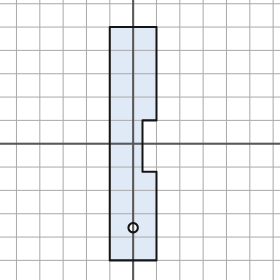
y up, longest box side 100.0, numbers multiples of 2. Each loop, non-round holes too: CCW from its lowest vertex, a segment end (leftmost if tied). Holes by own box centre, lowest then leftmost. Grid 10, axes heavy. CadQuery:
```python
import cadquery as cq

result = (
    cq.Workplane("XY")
    .moveTo(-10.0, -50.0)
    .lineTo(10.0, -50.0)
    .lineTo(10.0, -12.0)
    .lineTo(4.0, -12.0)
    .lineTo(4.0, 10.0)
    .lineTo(10.0, 10.0)
    .lineTo(10.0, 50.0)
    .lineTo(-10.0, 50.0)
    .close()
    .moveTo(0.0, -36.0)
    .circle(2.0)
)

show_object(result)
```